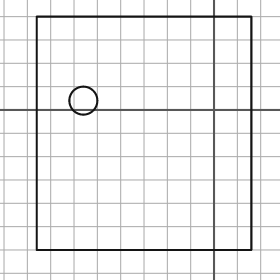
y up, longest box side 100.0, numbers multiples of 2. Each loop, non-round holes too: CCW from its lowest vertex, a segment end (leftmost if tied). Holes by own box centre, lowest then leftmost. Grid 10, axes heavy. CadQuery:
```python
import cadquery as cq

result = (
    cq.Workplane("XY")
    .moveTo(-76.0, -60.0)
    .lineTo(16.0, -60.0)
    .lineTo(16.0, 40.0)
    .lineTo(-76.0, 40.0)
    .close()
    .moveTo(-56.0, 4.0)
    .circle(6.0)
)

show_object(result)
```